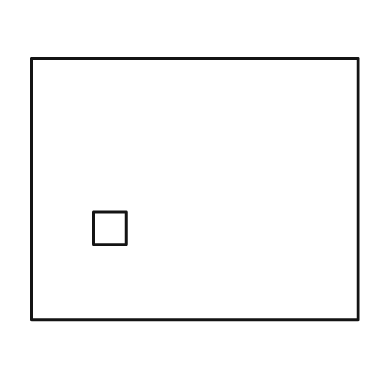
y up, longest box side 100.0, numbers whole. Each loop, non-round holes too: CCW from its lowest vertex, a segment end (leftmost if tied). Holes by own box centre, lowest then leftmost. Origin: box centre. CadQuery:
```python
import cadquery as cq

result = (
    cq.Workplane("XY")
    .moveTo(-50.0, -40.0)
    .lineTo(50.0, -40.0)
    .lineTo(50.0, 40.0)
    .lineTo(-50.0, 40.0)
    .close()
    .moveTo(-31.0, -17.0)
    .lineTo(-21.0, -17.0)
    .lineTo(-21.0, -7.0)
    .lineTo(-31.0, -7.0)
    .close()
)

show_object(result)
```